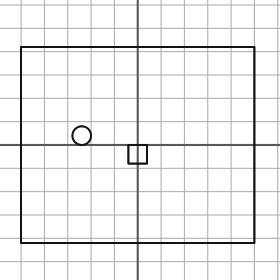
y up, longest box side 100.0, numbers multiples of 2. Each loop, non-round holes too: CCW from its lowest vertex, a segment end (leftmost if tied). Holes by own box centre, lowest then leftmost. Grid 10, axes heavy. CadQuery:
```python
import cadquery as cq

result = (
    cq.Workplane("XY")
    .moveTo(-50.0, -42.0)
    .lineTo(50.0, -42.0)
    .lineTo(50.0, 42.0)
    .lineTo(-50.0, 42.0)
    .close()
    .moveTo(-4.0, -8.0)
    .lineTo(4.0, -8.0)
    .lineTo(4.0, 0.0)
    .lineTo(-4.0, 0.0)
    .close()
    .moveTo(-24.0, 4.0)
    .circle(4.0)
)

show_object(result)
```